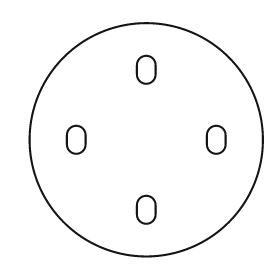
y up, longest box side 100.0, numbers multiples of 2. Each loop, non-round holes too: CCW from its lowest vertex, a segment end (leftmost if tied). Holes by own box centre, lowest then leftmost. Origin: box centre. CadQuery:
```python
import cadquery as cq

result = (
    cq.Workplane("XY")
    .moveTo(0.0, 0.0)
    .circle(50.0)
    .moveTo(-4.0, -32.0)
    .threePointArc((0.0, -36.0), (4.0, -32.0))
    .lineTo(4.0, -28.0)
    .threePointArc((0.0, -24.0), (-4.0, -28.0))
    .close()
    .moveTo(-34.0, -2.0)
    .threePointArc((-30.0, -6.0), (-26.0, -2.0))
    .lineTo(-26.0, 2.0)
    .threePointArc((-30.0, 6.0), (-34.0, 2.0))
    .close()
    .moveTo(26.0, -2.0)
    .threePointArc((30.0, -6.0), (34.0, -2.0))
    .lineTo(34.0, 2.0)
    .threePointArc((30.0, 6.0), (26.0, 2.0))
    .close()
    .moveTo(-4.0, 28.0)
    .threePointArc((0.0, 24.0), (4.0, 28.0))
    .lineTo(4.0, 32.0)
    .threePointArc((0.0, 36.0), (-4.0, 32.0))
    .close()
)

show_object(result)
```